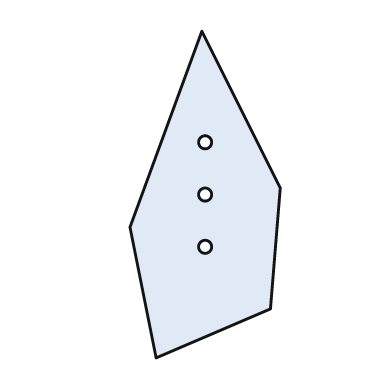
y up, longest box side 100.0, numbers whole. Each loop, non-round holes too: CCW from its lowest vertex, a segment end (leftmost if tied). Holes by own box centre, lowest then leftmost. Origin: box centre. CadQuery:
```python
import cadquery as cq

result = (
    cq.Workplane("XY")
    .moveTo(-15.0, -50.0)
    .lineTo(20.0, -35.0)
    .lineTo(23.0, 2.0)
    .lineTo(-1.0, 50.0)
    .lineTo(-23.0, -10.0)
    .close()
    .moveTo(0.0, -16.0)
    .circle(2.0)
    .moveTo(0.0, 0.0)
    .circle(2.0)
    .moveTo(0.0, 16.0)
    .circle(2.0)
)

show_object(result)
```